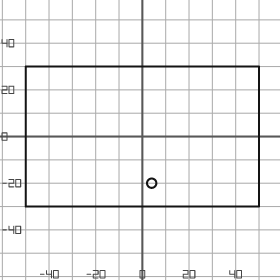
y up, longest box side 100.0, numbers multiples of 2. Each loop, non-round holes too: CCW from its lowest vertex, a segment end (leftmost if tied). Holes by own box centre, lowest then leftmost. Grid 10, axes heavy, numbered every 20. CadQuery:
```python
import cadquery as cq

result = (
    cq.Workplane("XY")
    .moveTo(-50.0, -30.0)
    .lineTo(50.0, -30.0)
    .lineTo(50.0, 30.0)
    .lineTo(-50.0, 30.0)
    .close()
    .moveTo(4.0, -20.0)
    .circle(2.0)
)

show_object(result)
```